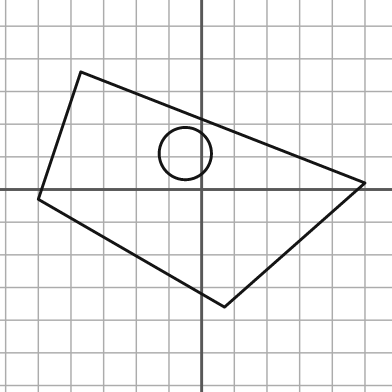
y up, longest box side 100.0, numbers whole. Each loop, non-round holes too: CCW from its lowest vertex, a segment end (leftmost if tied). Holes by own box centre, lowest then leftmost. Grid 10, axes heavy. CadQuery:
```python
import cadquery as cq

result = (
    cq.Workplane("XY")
    .moveTo(7.0, -36.0)
    .lineTo(50.0, 2.0)
    .lineTo(-37.0, 36.0)
    .lineTo(-50.0, -3.0)
    .close()
    .moveTo(-5.0, 11.0)
    .circle(8.0)
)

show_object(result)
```